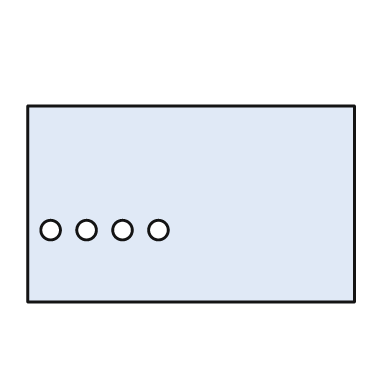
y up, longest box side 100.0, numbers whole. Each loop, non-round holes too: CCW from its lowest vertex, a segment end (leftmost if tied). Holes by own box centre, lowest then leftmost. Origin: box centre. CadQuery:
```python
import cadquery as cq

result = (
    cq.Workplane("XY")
    .moveTo(-50.0, -30.0)
    .lineTo(50.0, -30.0)
    .lineTo(50.0, 30.0)
    .lineTo(-50.0, 30.0)
    .close()
    .moveTo(-43.0, -8.0)
    .circle(3.0)
    .moveTo(-32.0, -8.0)
    .circle(3.0)
    .moveTo(-21.0, -8.0)
    .circle(3.0)
    .moveTo(-10.0, -8.0)
    .circle(3.0)
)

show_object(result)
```